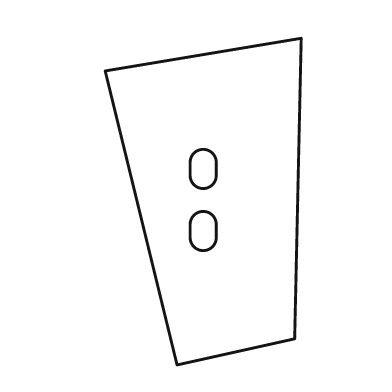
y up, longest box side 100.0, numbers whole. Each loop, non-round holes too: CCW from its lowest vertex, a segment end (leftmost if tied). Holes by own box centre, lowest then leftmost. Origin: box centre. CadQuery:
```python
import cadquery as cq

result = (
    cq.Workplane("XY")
    .moveTo(-8.0, -50.0)
    .lineTo(28.0, -42.0)
    .lineTo(30.0, 50.0)
    .lineTo(-30.0, 40.0)
    .close()
    .moveTo(-4.0, -11.0)
    .threePointArc((0.0, -15.0), (4.0, -11.0))
    .lineTo(4.0, -7.0)
    .threePointArc((0.0, -3.0), (-4.0, -7.0))
    .close()
    .moveTo(-4.0, 8.0)
    .threePointArc((0.0, 4.0), (4.0, 8.0))
    .lineTo(4.0, 12.0)
    .threePointArc((0.0, 16.0), (-4.0, 12.0))
    .close()
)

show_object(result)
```